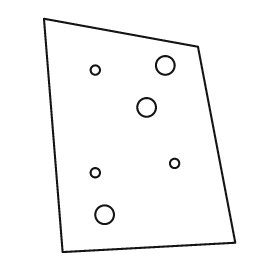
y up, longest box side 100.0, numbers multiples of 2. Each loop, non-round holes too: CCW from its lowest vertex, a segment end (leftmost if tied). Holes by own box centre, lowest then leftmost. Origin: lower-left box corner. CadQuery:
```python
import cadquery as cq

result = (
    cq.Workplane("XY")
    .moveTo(8.0, 0.0)
    .lineTo(82.0, 4.0)
    .lineTo(66.0, 88.0)
    .lineTo(0.0, 100.0)
    .close()
    .moveTo(26.0, 16.0)
    .circle(4.0)
    .moveTo(22.0, 34.0)
    .circle(2.0)
    .moveTo(56.0, 38.0)
    .circle(2.0)
    .moveTo(44.0, 62.0)
    .circle(4.0)
    .moveTo(22.0, 78.0)
    .circle(2.0)
    .moveTo(52.0, 80.0)
    .circle(4.0)
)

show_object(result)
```